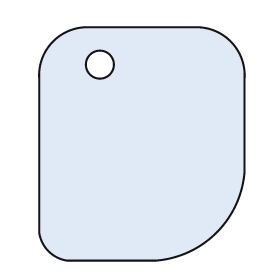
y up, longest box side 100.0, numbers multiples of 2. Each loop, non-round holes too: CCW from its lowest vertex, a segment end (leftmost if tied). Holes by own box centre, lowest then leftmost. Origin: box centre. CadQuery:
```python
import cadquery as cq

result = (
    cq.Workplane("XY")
    .moveTo(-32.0, -50.0)
    .lineTo(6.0, -50.0)
    .threePointArc((32.0, -38.0), (44.0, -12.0))
    .lineTo(44.0, 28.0)
    .threePointArc((38.0, 44.0), (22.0, 50.0))
    .lineTo(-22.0, 50.0)
    .threePointArc((-38.0, 44.0), (-44.0, 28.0))
    .lineTo(-44.0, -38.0)
    .threePointArc((-40.0, -46.0), (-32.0, -50.0))
    .close()
    .moveTo(-18.0, 34.0)
    .circle(6.0)
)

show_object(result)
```